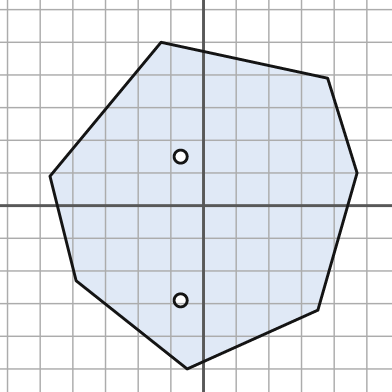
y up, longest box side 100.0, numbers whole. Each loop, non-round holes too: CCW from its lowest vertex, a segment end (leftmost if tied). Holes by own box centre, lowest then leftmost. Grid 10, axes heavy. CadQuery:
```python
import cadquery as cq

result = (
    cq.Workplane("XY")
    .moveTo(-5.0, -50.0)
    .lineTo(35.0, -32.0)
    .lineTo(47.0, 10.0)
    .lineTo(38.0, 39.0)
    .lineTo(-13.0, 50.0)
    .lineTo(-47.0, 9.0)
    .lineTo(-39.0, -23.0)
    .close()
    .moveTo(-7.0, -29.0)
    .circle(2.0)
    .moveTo(-7.0, 15.0)
    .circle(2.0)
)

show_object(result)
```